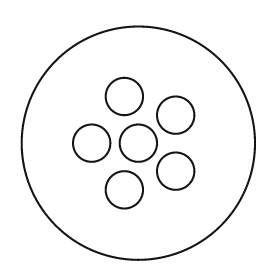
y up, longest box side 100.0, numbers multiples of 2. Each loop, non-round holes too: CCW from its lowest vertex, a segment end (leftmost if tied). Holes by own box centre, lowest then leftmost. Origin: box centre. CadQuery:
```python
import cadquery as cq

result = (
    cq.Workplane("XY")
    .moveTo(0.0, 0.0)
    .circle(50.0)
    .moveTo(-6.0, -20.0)
    .circle(8.0)
    .moveTo(16.0, -12.0)
    .circle(8.0)
    .moveTo(-20.0, 0.0)
    .circle(8.0)
    .moveTo(0.0, 0.0)
    .circle(8.0)
    .moveTo(16.0, 12.0)
    .circle(8.0)
    .moveTo(-6.0, 20.0)
    .circle(8.0)
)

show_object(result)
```